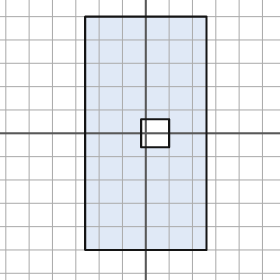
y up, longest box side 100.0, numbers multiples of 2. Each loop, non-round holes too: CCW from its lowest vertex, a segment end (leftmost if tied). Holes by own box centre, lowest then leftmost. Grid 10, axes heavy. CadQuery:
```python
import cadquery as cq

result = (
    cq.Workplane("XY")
    .moveTo(-26.0, -50.0)
    .lineTo(26.0, -50.0)
    .lineTo(26.0, 50.0)
    .lineTo(-26.0, 50.0)
    .close()
    .moveTo(-2.0, -6.0)
    .lineTo(10.0, -6.0)
    .lineTo(10.0, 6.0)
    .lineTo(-2.0, 6.0)
    .close()
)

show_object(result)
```